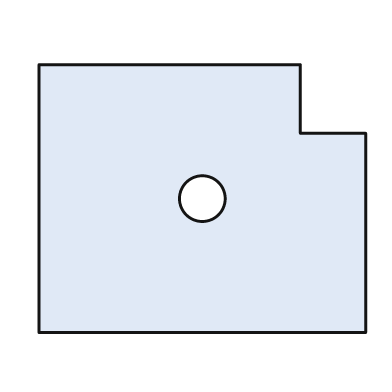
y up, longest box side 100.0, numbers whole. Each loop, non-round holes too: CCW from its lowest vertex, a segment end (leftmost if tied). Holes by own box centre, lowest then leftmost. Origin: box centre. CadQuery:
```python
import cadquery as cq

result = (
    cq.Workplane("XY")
    .moveTo(-50.0, -41.0)
    .lineTo(50.0, -41.0)
    .lineTo(50.0, 20.0)
    .lineTo(30.0, 20.0)
    .lineTo(30.0, 41.0)
    .lineTo(-50.0, 41.0)
    .close()
    .moveTo(0.0, 0.0)
    .circle(7.0)
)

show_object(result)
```